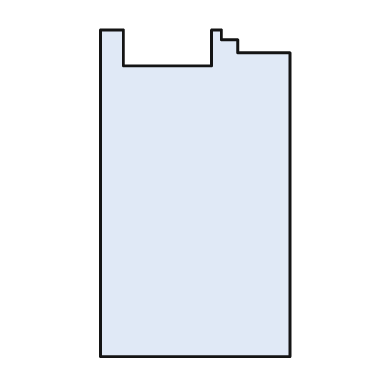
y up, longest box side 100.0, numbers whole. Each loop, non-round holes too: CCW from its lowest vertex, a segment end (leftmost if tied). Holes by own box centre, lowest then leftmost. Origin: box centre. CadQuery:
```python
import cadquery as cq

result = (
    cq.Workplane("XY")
    .moveTo(-29.0, -50.0)
    .lineTo(29.0, -50.0)
    .lineTo(29.0, 43.0)
    .lineTo(13.0, 43.0)
    .lineTo(13.0, 47.0)
    .lineTo(8.0, 47.0)
    .lineTo(8.0, 50.0)
    .lineTo(5.0, 50.0)
    .lineTo(5.0, 39.0)
    .lineTo(-22.0, 39.0)
    .lineTo(-22.0, 50.0)
    .lineTo(-29.0, 50.0)
    .close()
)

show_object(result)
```